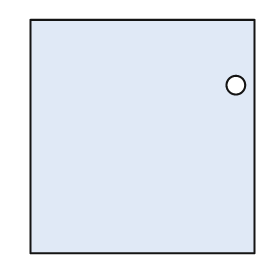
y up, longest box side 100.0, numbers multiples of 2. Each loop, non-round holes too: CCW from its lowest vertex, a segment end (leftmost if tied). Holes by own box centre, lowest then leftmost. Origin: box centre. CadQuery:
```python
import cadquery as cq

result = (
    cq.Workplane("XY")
    .moveTo(-48.0, -50.0)
    .lineTo(48.0, -50.0)
    .lineTo(48.0, 50.0)
    .lineTo(-48.0, 50.0)
    .close()
    .moveTo(40.0, 22.0)
    .circle(4.0)
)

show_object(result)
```